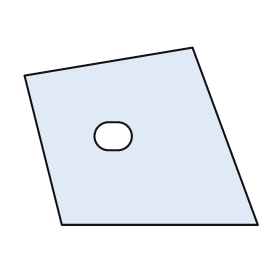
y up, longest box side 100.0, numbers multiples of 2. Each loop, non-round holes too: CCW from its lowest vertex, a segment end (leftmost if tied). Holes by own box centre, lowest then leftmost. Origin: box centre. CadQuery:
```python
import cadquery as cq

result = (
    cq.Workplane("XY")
    .moveTo(-34.0, -38.0)
    .lineTo(50.0, -38.0)
    .lineTo(22.0, 38.0)
    .lineTo(-50.0, 26.0)
    .close()
    .moveTo(-14.0, -6.0)
    .lineTo(-10.0, -6.0)
    .threePointArc((-4.0, 0.0), (-10.0, 6.0))
    .lineTo(-14.0, 6.0)
    .threePointArc((-20.0, 0.0), (-14.0, -6.0))
    .close()
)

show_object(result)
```